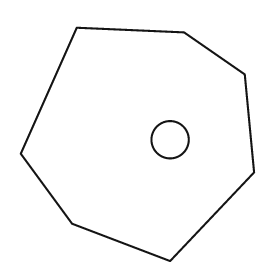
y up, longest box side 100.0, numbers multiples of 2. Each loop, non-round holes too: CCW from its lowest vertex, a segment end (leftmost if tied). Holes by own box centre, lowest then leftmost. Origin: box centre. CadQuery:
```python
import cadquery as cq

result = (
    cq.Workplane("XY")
    .moveTo(14.0, -50.0)
    .lineTo(50.0, -12.0)
    .lineTo(46.0, 30.0)
    .lineTo(20.0, 48.0)
    .lineTo(-26.0, 50.0)
    .lineTo(-50.0, -4.0)
    .lineTo(-28.0, -34.0)
    .close()
    .moveTo(14.0, 2.0)
    .circle(8.0)
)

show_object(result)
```